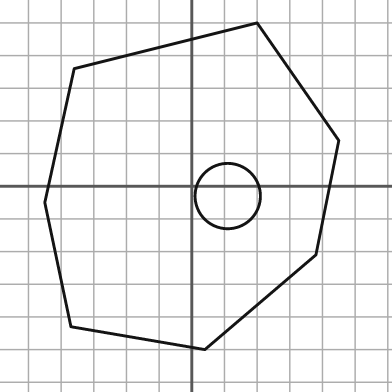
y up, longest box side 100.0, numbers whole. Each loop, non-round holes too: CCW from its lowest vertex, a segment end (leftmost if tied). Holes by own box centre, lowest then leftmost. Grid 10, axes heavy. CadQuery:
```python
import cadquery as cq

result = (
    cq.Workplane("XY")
    .moveTo(4.0, -50.0)
    .lineTo(38.0, -21.0)
    .lineTo(45.0, 14.0)
    .lineTo(20.0, 50.0)
    .lineTo(-36.0, 36.0)
    .lineTo(-45.0, -5.0)
    .lineTo(-37.0, -43.0)
    .close()
    .moveTo(11.0, -3.0)
    .circle(10.0)
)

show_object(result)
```